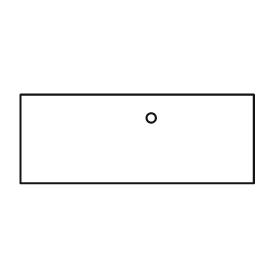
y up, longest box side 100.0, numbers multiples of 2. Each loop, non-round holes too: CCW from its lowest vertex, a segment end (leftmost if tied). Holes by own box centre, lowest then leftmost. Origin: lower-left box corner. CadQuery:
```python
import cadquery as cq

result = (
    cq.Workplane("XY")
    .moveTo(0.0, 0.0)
    .lineTo(100.0, 0.0)
    .lineTo(100.0, 38.0)
    .lineTo(0.0, 38.0)
    .close()
    .moveTo(56.0, 28.0)
    .circle(2.0)
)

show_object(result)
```